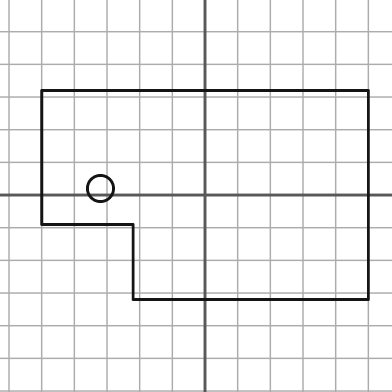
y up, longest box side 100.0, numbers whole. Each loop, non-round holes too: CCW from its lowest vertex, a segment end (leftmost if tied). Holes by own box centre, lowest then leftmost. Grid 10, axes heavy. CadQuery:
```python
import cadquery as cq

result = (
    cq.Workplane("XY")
    .moveTo(-22.0, -32.0)
    .lineTo(50.0, -32.0)
    .lineTo(50.0, 32.0)
    .lineTo(-50.0, 32.0)
    .lineTo(-50.0, -9.0)
    .lineTo(-22.0, -9.0)
    .close()
    .moveTo(-32.0, 2.0)
    .circle(4.0)
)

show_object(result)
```